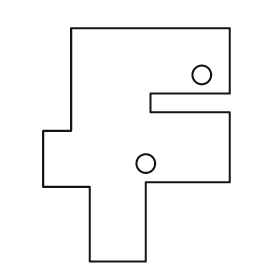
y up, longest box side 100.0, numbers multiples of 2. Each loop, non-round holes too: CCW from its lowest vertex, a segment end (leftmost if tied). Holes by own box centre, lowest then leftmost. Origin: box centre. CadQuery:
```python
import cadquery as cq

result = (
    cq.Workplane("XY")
    .moveTo(-20.0, -50.0)
    .lineTo(4.0, -50.0)
    .lineTo(4.0, -16.0)
    .lineTo(40.0, -16.0)
    .lineTo(40.0, 14.0)
    .lineTo(6.0, 14.0)
    .lineTo(6.0, 22.0)
    .lineTo(40.0, 22.0)
    .lineTo(40.0, 50.0)
    .lineTo(-28.0, 50.0)
    .lineTo(-28.0, 6.0)
    .lineTo(-40.0, 6.0)
    .lineTo(-40.0, -18.0)
    .lineTo(-20.0, -18.0)
    .close()
    .moveTo(4.0, -8.0)
    .circle(4.0)
    .moveTo(28.0, 30.0)
    .circle(4.0)
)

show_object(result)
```